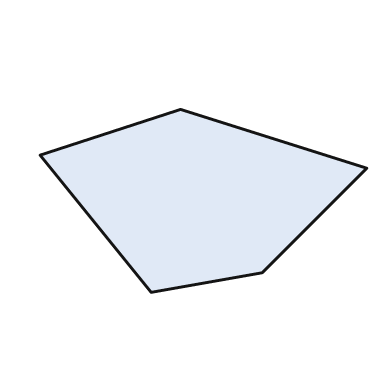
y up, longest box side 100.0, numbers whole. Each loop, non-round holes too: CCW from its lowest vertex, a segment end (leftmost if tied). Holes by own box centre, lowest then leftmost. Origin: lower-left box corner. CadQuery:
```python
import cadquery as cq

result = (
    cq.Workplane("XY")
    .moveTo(34.0, 0.0)
    .lineTo(68.0, 6.0)
    .lineTo(100.0, 38.0)
    .lineTo(43.0, 56.0)
    .lineTo(0.0, 42.0)
    .close()
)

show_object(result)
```